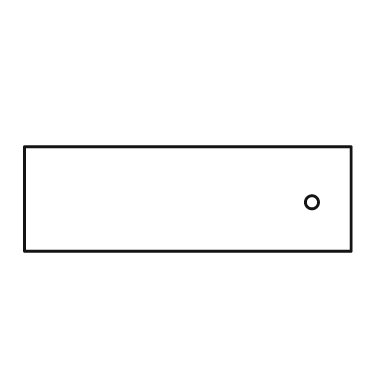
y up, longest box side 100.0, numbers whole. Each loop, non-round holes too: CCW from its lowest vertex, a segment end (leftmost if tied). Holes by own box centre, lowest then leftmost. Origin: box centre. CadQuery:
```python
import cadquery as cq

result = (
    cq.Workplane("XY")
    .moveTo(-50.0, -16.0)
    .lineTo(50.0, -16.0)
    .lineTo(50.0, 16.0)
    .lineTo(-50.0, 16.0)
    .close()
    .moveTo(38.0, -1.0)
    .circle(2.0)
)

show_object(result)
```